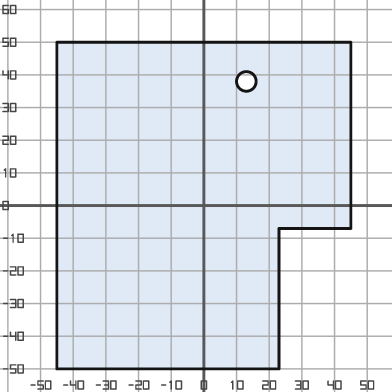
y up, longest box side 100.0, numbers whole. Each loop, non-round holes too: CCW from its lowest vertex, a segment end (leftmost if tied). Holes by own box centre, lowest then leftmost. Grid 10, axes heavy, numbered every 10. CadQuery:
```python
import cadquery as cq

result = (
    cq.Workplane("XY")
    .moveTo(-45.0, -50.0)
    .lineTo(23.0, -50.0)
    .lineTo(23.0, -7.0)
    .lineTo(45.0, -7.0)
    .lineTo(45.0, 50.0)
    .lineTo(-45.0, 50.0)
    .close()
    .moveTo(13.0, 38.0)
    .circle(3.0)
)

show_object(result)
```